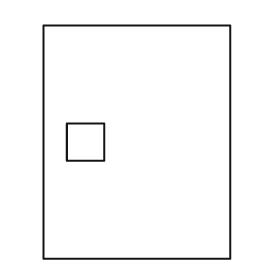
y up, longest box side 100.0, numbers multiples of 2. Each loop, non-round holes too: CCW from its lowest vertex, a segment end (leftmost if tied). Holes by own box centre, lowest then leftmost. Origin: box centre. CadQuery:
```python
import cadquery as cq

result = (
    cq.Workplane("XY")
    .moveTo(-40.0, -50.0)
    .lineTo(40.0, -50.0)
    .lineTo(40.0, 50.0)
    .lineTo(-40.0, 50.0)
    .close()
    .moveTo(-30.0, -8.0)
    .lineTo(-14.0, -8.0)
    .lineTo(-14.0, 8.0)
    .lineTo(-30.0, 8.0)
    .close()
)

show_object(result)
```